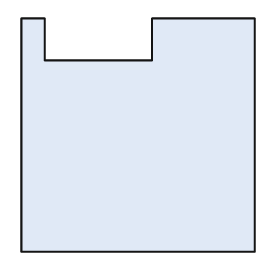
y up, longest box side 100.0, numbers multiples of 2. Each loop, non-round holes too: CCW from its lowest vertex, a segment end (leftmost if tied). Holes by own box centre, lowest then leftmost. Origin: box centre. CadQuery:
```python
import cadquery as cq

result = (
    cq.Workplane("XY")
    .moveTo(-50.0, -50.0)
    .lineTo(50.0, -50.0)
    .lineTo(50.0, 50.0)
    .lineTo(6.0, 50.0)
    .lineTo(6.0, 32.0)
    .lineTo(-40.0, 32.0)
    .lineTo(-40.0, 50.0)
    .lineTo(-50.0, 50.0)
    .close()
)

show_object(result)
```